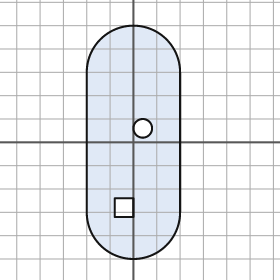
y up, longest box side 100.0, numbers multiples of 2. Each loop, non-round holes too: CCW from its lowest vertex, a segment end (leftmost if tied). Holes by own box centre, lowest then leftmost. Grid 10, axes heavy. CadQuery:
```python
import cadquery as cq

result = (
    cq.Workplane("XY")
    .moveTo(-20.0, -30.0)
    .threePointArc((0.0, -50.0), (20.0, -30.0))
    .lineTo(20.0, 30.0)
    .threePointArc((0.0, 50.0), (-20.0, 30.0))
    .close()
    .moveTo(-8.0, -32.0)
    .lineTo(0.0, -32.0)
    .lineTo(0.0, -24.0)
    .lineTo(-8.0, -24.0)
    .close()
    .moveTo(4.0, 6.0)
    .circle(4.0)
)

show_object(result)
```